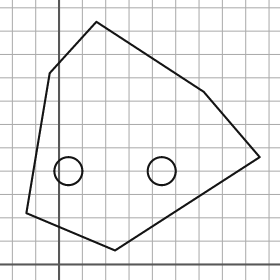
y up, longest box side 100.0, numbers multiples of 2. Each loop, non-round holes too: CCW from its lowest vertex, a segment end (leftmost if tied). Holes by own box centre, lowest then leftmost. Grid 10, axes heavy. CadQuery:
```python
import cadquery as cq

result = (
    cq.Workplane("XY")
    .moveTo(24.0, 6.0)
    .lineTo(86.0, 46.0)
    .lineTo(62.0, 74.0)
    .lineTo(16.0, 104.0)
    .lineTo(-4.0, 82.0)
    .lineTo(-14.0, 22.0)
    .close()
    .moveTo(4.0, 40.0)
    .circle(6.0)
    .moveTo(44.0, 40.0)
    .circle(6.0)
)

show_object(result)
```